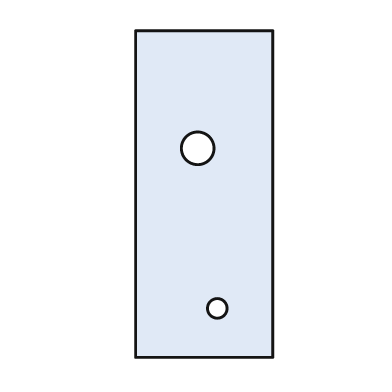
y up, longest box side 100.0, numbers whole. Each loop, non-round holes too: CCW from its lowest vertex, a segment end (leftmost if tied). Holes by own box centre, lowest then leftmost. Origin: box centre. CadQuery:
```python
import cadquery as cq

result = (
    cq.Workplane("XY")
    .moveTo(-21.0, -50.0)
    .lineTo(21.0, -50.0)
    .lineTo(21.0, 50.0)
    .lineTo(-21.0, 50.0)
    .close()
    .moveTo(4.0, -35.0)
    .circle(3.0)
    .moveTo(-2.0, 14.0)
    .circle(5.0)
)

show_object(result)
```